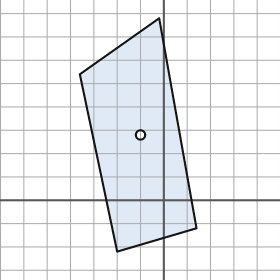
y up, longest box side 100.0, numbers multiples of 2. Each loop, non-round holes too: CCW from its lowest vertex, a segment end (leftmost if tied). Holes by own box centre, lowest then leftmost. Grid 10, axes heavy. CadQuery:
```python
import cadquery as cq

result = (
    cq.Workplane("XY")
    .moveTo(-20.0, -22.0)
    .lineTo(14.0, -12.0)
    .lineTo(-2.0, 78.0)
    .lineTo(-36.0, 54.0)
    .close()
    .moveTo(-10.0, 28.0)
    .circle(2.0)
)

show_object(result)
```